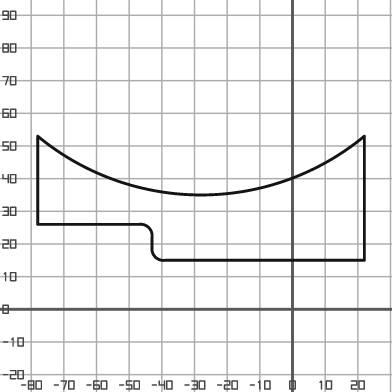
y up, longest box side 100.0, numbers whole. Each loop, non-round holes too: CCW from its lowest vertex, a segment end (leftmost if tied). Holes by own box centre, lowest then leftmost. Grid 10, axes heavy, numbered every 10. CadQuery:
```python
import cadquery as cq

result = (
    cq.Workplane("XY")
    .moveTo(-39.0, 15.0)
    .lineTo(22.0, 15.0)
    .lineTo(22.0, 53.0)
    .threePointArc((-28.0, 35.0), (-78.0, 53.0))
    .lineTo(-78.0, 26.0)
    .lineTo(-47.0, 26.0)
    .threePointArc((-44.0, 25.0), (-43.0, 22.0))
    .lineTo(-43.0, 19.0)
    .threePointArc((-42.0, 16.0), (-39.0, 15.0))
    .close()
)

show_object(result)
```